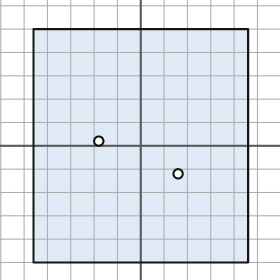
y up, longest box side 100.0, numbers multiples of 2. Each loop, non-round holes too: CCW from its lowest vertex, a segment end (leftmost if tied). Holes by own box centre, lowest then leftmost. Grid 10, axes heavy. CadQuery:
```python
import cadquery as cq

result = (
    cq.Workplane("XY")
    .moveTo(-46.0, -50.0)
    .lineTo(46.0, -50.0)
    .lineTo(46.0, 50.0)
    .lineTo(-46.0, 50.0)
    .close()
    .moveTo(16.0, -12.0)
    .circle(2.0)
    .moveTo(-18.0, 2.0)
    .circle(2.0)
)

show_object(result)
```